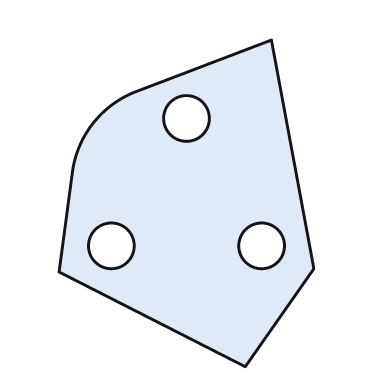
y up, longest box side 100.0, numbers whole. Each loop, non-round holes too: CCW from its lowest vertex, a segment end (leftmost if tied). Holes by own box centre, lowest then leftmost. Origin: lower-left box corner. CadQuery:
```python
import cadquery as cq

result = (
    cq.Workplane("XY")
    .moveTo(57.0, 0.0)
    .lineTo(78.0, 30.0)
    .lineTo(65.0, 100.0)
    .lineTo(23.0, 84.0)
    .threePointArc((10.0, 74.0), (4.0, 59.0))
    .lineTo(0.0, 29.0)
    .close()
    .moveTo(16.0, 37.0)
    .circle(7.0)
    .moveTo(62.0, 37.0)
    .circle(7.0)
    .moveTo(39.0, 76.0)
    .circle(7.0)
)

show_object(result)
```